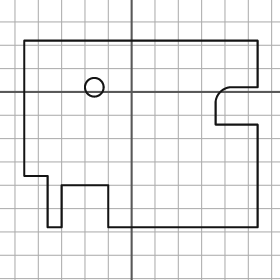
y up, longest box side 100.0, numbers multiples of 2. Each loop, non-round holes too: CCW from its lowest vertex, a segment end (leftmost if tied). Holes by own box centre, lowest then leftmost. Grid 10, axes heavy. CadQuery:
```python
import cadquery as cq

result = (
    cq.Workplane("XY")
    .moveTo(-36.0, -58.0)
    .lineTo(-30.0, -58.0)
    .lineTo(-30.0, -40.0)
    .lineTo(-10.0, -40.0)
    .lineTo(-10.0, -58.0)
    .lineTo(54.0, -58.0)
    .lineTo(54.0, -14.0)
    .lineTo(36.0, -14.0)
    .lineTo(36.0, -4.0)
    .threePointArc((38.0, 0.0), (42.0, 2.0))
    .lineTo(54.0, 2.0)
    .lineTo(54.0, 22.0)
    .lineTo(-46.0, 22.0)
    .lineTo(-46.0, -36.0)
    .lineTo(-36.0, -36.0)
    .close()
    .moveTo(-16.0, 2.0)
    .circle(4.0)
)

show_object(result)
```